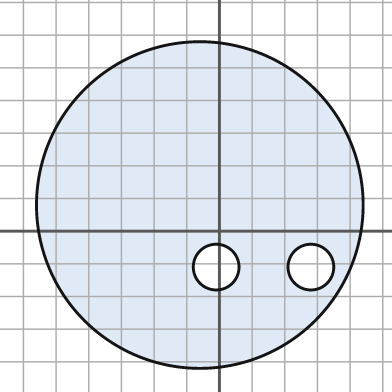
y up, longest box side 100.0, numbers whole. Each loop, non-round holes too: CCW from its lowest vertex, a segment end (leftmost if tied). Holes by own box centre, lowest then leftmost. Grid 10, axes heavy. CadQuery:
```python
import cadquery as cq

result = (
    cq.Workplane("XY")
    .moveTo(-6.0, 8.0)
    .circle(50.0)
    .moveTo(-1.0, -11.0)
    .circle(7.0)
    .moveTo(28.0, -11.0)
    .circle(7.0)
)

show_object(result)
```